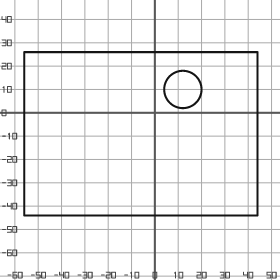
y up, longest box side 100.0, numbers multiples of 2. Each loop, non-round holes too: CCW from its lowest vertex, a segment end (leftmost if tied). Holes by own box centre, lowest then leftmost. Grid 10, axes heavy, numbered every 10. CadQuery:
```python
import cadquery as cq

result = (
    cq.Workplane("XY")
    .moveTo(-56.0, -44.0)
    .lineTo(44.0, -44.0)
    .lineTo(44.0, 26.0)
    .lineTo(-56.0, 26.0)
    .close()
    .moveTo(12.0, 10.0)
    .circle(8.0)
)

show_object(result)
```